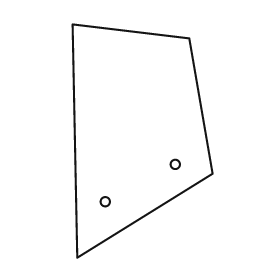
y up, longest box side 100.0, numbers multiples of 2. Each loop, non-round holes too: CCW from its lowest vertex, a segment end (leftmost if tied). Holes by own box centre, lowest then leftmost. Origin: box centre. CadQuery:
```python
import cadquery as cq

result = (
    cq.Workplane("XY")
    .moveTo(-28.0, -50.0)
    .lineTo(30.0, -14.0)
    .lineTo(20.0, 44.0)
    .lineTo(-30.0, 50.0)
    .close()
    .moveTo(-16.0, -26.0)
    .circle(2.0)
    .moveTo(14.0, -10.0)
    .circle(2.0)
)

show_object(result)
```